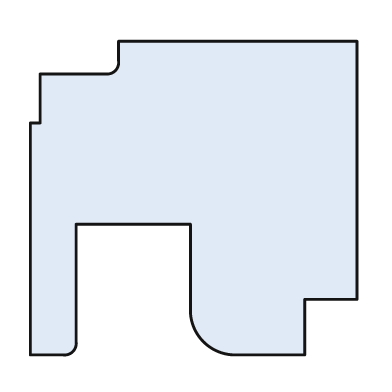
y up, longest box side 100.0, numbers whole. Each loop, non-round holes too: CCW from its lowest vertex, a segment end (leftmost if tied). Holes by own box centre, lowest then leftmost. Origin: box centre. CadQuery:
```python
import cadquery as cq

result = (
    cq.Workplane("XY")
    .moveTo(-50.0, -48.0)
    .lineTo(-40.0, -48.0)
    .threePointArc((-37.0, -47.0), (-36.0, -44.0))
    .lineTo(-36.0, -8.0)
    .lineTo(-1.0, -8.0)
    .lineTo(-1.0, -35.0)
    .threePointArc((3.0, -44.0), (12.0, -48.0))
    .lineTo(34.0, -48.0)
    .lineTo(34.0, -31.0)
    .lineTo(50.0, -31.0)
    .lineTo(50.0, 48.0)
    .lineTo(-23.0, 48.0)
    .lineTo(-23.0, 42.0)
    .threePointArc((-24.0, 39.0), (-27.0, 38.0))
    .lineTo(-47.0, 38.0)
    .lineTo(-47.0, 23.0)
    .lineTo(-50.0, 23.0)
    .close()
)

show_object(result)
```